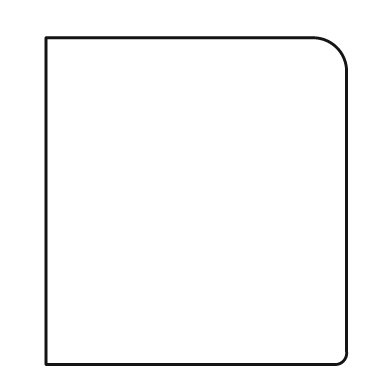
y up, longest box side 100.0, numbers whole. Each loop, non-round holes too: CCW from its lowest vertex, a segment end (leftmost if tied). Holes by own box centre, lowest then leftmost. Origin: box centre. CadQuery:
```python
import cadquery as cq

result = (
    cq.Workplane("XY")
    .moveTo(-46.0, -50.0)
    .lineTo(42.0, -50.0)
    .threePointArc((45.0, -49.0), (46.0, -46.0))
    .lineTo(46.0, 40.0)
    .threePointArc((43.0, 47.0), (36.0, 50.0))
    .lineTo(-46.0, 50.0)
    .close()
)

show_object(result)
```